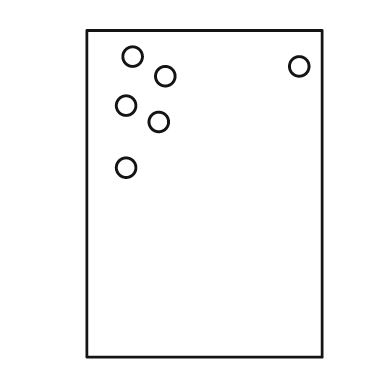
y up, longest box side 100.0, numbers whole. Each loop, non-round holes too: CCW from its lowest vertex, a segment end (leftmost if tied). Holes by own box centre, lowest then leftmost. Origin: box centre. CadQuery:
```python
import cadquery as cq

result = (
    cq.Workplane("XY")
    .moveTo(-36.0, -50.0)
    .lineTo(36.0, -50.0)
    .lineTo(36.0, 50.0)
    .lineTo(-36.0, 50.0)
    .close()
    .moveTo(-24.0, 8.0)
    .circle(3.0)
    .moveTo(-14.0, 22.0)
    .circle(3.0)
    .moveTo(-24.0, 27.0)
    .circle(3.0)
    .moveTo(-12.0, 36.0)
    .circle(3.0)
    .moveTo(29.0, 39.0)
    .circle(3.0)
    .moveTo(-22.0, 42.0)
    .circle(3.0)
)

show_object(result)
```